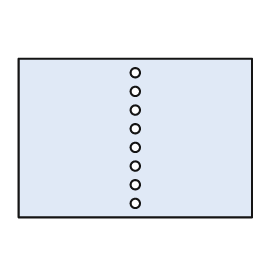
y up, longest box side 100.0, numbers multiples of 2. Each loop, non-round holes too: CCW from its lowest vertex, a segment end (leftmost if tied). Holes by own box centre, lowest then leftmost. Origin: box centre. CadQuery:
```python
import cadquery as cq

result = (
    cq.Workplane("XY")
    .moveTo(-50.0, -34.0)
    .lineTo(50.0, -34.0)
    .lineTo(50.0, 34.0)
    .lineTo(-50.0, 34.0)
    .close()
    .moveTo(0.0, -28.0)
    .circle(2.0)
    .moveTo(0.0, -20.0)
    .circle(2.0)
    .moveTo(0.0, -12.0)
    .circle(2.0)
    .moveTo(0.0, -4.0)
    .circle(2.0)
    .moveTo(0.0, 4.0)
    .circle(2.0)
    .moveTo(0.0, 12.0)
    .circle(2.0)
    .moveTo(0.0, 20.0)
    .circle(2.0)
    .moveTo(0.0, 28.0)
    .circle(2.0)
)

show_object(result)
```